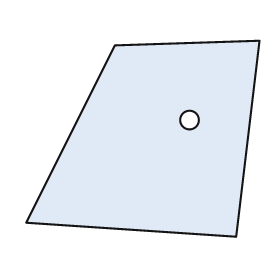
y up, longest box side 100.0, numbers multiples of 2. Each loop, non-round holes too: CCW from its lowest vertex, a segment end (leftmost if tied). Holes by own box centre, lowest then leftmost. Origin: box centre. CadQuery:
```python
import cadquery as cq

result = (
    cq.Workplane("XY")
    .moveTo(40.0, -42.0)
    .lineTo(50.0, 42.0)
    .lineTo(-12.0, 40.0)
    .lineTo(-50.0, -36.0)
    .close()
    .moveTo(20.0, 8.0)
    .circle(4.0)
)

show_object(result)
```